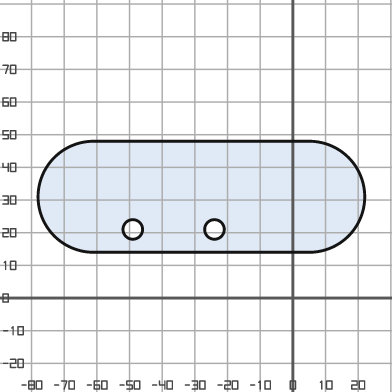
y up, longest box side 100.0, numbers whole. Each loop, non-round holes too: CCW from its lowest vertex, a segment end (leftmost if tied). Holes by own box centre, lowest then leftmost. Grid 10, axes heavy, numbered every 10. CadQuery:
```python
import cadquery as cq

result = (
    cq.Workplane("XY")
    .moveTo(-61.0, 14.0)
    .lineTo(5.0, 14.0)
    .threePointArc((22.0, 31.0), (5.0, 48.0))
    .lineTo(-61.0, 48.0)
    .threePointArc((-78.0, 31.0), (-61.0, 14.0))
    .close()
    .moveTo(-49.0, 21.0)
    .circle(3.0)
    .moveTo(-24.0, 21.0)
    .circle(3.0)
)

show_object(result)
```